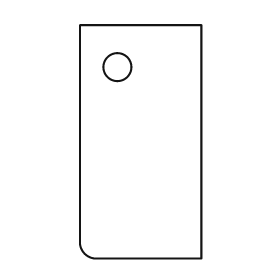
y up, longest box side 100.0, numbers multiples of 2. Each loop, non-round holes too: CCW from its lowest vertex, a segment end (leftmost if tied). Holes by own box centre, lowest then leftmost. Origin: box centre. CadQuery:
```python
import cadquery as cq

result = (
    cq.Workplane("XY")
    .moveTo(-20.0, -50.0)
    .lineTo(26.0, -50.0)
    .lineTo(26.0, 50.0)
    .lineTo(-26.0, 50.0)
    .lineTo(-26.0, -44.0)
    .threePointArc((-24.0, -48.0), (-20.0, -50.0))
    .close()
    .moveTo(-10.0, 32.0)
    .circle(6.0)
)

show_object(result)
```